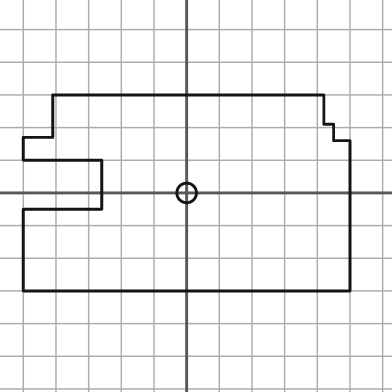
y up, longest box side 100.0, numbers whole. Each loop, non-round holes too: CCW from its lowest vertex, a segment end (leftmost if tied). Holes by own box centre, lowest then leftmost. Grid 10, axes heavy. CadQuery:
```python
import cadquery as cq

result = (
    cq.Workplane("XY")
    .moveTo(-50.0, -30.0)
    .lineTo(50.0, -30.0)
    .lineTo(50.0, 16.0)
    .lineTo(45.0, 16.0)
    .lineTo(45.0, 21.0)
    .lineTo(42.0, 21.0)
    .lineTo(42.0, 30.0)
    .lineTo(-41.0, 30.0)
    .lineTo(-41.0, 17.0)
    .lineTo(-50.0, 17.0)
    .lineTo(-50.0, 10.0)
    .lineTo(-26.0, 10.0)
    .lineTo(-26.0, -5.0)
    .lineTo(-50.0, -5.0)
    .close()
    .moveTo(0.0, 0.0)
    .circle(3.0)
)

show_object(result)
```